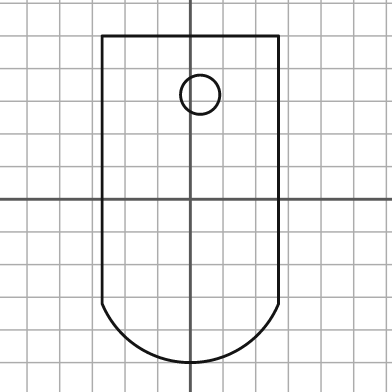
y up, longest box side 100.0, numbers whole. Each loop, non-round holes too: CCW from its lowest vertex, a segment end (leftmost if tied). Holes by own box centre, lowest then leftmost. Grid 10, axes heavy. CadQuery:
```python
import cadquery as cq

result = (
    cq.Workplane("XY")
    .moveTo(-27.0, -32.0)
    .threePointArc((0.0, -50.0), (27.0, -32.0))
    .lineTo(27.0, 50.0)
    .lineTo(-27.0, 50.0)
    .close()
    .moveTo(3.0, 32.0)
    .circle(6.0)
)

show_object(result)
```